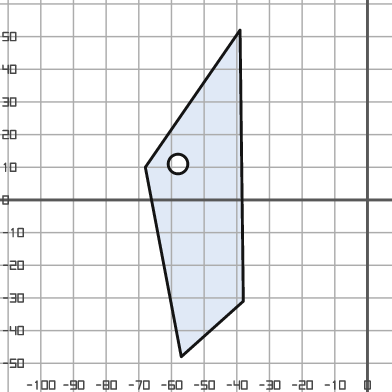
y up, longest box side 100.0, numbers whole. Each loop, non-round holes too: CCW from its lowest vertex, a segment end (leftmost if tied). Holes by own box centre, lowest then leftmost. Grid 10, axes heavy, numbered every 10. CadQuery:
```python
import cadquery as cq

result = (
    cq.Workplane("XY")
    .moveTo(-57.0, -48.0)
    .lineTo(-38.0, -31.0)
    .lineTo(-39.0, 52.0)
    .lineTo(-68.0, 10.0)
    .close()
    .moveTo(-58.0, 11.0)
    .circle(3.0)
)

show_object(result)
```